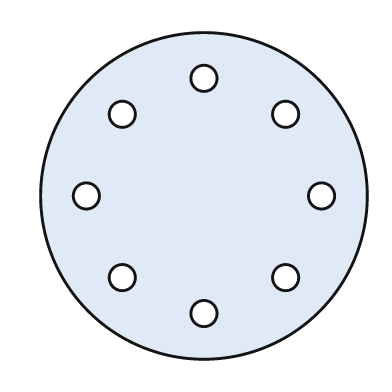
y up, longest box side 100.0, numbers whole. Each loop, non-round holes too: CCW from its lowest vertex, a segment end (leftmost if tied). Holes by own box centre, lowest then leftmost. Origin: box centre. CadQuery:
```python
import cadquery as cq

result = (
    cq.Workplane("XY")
    .moveTo(0.0, 0.0)
    .circle(50.0)
    .moveTo(0.0, -36.0)
    .circle(4.0)
    .moveTo(-25.0, -25.0)
    .circle(4.0)
    .moveTo(25.0, -25.0)
    .circle(4.0)
    .moveTo(-36.0, 0.0)
    .circle(4.0)
    .moveTo(36.0, 0.0)
    .circle(4.0)
    .moveTo(-25.0, 25.0)
    .circle(4.0)
    .moveTo(25.0, 25.0)
    .circle(4.0)
    .moveTo(0.0, 36.0)
    .circle(4.0)
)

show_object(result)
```